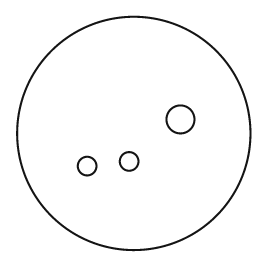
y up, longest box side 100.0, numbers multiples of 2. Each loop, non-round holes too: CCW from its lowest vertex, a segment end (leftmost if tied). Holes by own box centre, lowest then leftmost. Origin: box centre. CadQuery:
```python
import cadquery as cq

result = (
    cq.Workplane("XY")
    .moveTo(0.0, 0.0)
    .circle(50.0)
    .moveTo(-20.0, -14.0)
    .circle(4.0)
    .moveTo(-2.0, -12.0)
    .circle(4.0)
    .moveTo(20.0, 6.0)
    .circle(6.0)
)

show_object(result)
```